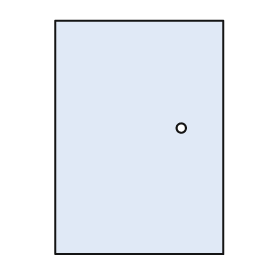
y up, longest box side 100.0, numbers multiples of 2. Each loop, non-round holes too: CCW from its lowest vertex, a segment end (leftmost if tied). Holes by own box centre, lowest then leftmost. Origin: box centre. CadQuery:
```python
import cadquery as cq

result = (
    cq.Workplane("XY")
    .moveTo(-36.0, -50.0)
    .lineTo(36.0, -50.0)
    .lineTo(36.0, 50.0)
    .lineTo(-36.0, 50.0)
    .close()
    .moveTo(18.0, 4.0)
    .circle(2.0)
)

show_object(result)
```